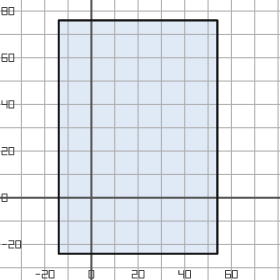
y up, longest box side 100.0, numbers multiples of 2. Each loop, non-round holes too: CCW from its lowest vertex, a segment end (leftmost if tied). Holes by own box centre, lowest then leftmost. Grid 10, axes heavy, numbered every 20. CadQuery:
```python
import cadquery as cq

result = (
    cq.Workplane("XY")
    .moveTo(-14.0, -24.0)
    .lineTo(54.0, -24.0)
    .lineTo(54.0, 76.0)
    .lineTo(-14.0, 76.0)
    .close()
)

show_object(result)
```